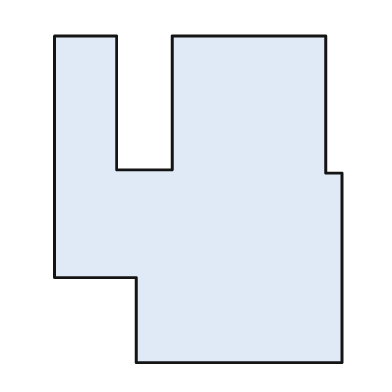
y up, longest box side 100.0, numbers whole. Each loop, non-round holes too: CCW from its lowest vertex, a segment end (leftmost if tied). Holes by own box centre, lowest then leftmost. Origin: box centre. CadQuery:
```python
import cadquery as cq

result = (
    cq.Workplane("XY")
    .moveTo(-19.0, -50.0)
    .lineTo(44.0, -50.0)
    .lineTo(44.0, 8.0)
    .lineTo(39.0, 8.0)
    .lineTo(39.0, 50.0)
    .lineTo(-8.0, 50.0)
    .lineTo(-8.0, 9.0)
    .lineTo(-25.0, 9.0)
    .lineTo(-25.0, 50.0)
    .lineTo(-44.0, 50.0)
    .lineTo(-44.0, -24.0)
    .lineTo(-19.0, -24.0)
    .close()
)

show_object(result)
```